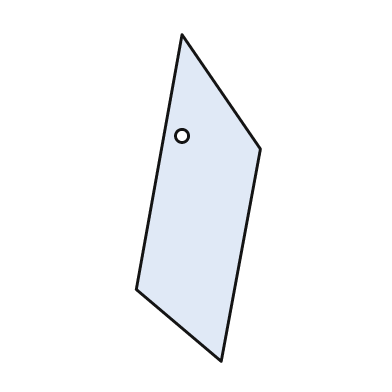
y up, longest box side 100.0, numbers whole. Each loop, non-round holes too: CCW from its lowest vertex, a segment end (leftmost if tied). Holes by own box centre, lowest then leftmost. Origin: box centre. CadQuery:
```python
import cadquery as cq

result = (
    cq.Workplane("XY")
    .moveTo(7.0, -50.0)
    .lineTo(19.0, 15.0)
    .lineTo(-5.0, 50.0)
    .lineTo(-19.0, -28.0)
    .close()
    .moveTo(-5.0, 19.0)
    .circle(2.0)
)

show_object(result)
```